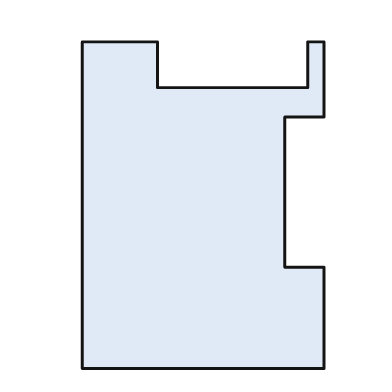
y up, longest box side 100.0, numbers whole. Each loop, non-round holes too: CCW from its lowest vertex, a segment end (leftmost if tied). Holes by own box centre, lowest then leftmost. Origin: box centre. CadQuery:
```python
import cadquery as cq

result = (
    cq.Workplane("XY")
    .moveTo(-37.0, -50.0)
    .lineTo(37.0, -50.0)
    .lineTo(37.0, -19.0)
    .lineTo(25.0, -19.0)
    .lineTo(25.0, 27.0)
    .lineTo(37.0, 27.0)
    .lineTo(37.0, 50.0)
    .lineTo(32.0, 50.0)
    .lineTo(32.0, 36.0)
    .lineTo(-14.0, 36.0)
    .lineTo(-14.0, 50.0)
    .lineTo(-37.0, 50.0)
    .close()
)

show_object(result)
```